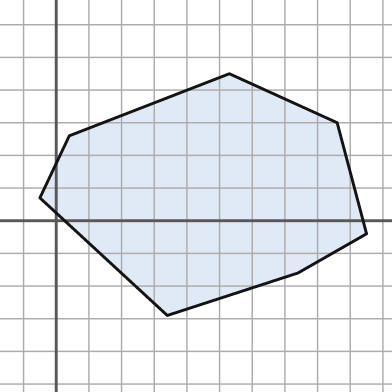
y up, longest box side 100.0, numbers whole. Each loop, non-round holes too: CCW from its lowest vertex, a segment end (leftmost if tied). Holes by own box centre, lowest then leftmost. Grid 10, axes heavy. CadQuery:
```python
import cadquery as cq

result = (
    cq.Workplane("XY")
    .moveTo(34.0, -29.0)
    .lineTo(74.0, -16.0)
    .lineTo(95.0, -4.0)
    .lineTo(86.0, 30.0)
    .lineTo(53.0, 45.0)
    .lineTo(4.0, 26.0)
    .lineTo(-5.0, 7.0)
    .close()
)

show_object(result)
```